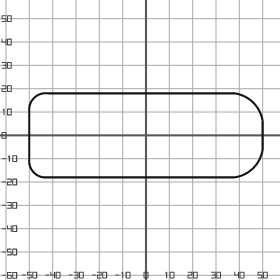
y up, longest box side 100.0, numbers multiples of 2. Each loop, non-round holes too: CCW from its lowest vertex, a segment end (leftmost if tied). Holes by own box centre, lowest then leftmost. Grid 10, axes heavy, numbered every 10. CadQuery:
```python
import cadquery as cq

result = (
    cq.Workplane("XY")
    .moveTo(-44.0, -18.0)
    .lineTo(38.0, -18.0)
    .threePointArc((46.0, -14.0), (50.0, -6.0))
    .lineTo(50.0, 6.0)
    .threePointArc((46.0, 14.0), (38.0, 18.0))
    .lineTo(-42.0, 18.0)
    .threePointArc((-48.0, 16.0), (-50.0, 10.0))
    .lineTo(-50.0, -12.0)
    .threePointArc((-48.0, -16.0), (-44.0, -18.0))
    .close()
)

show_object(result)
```